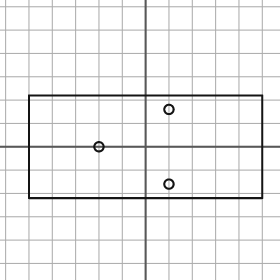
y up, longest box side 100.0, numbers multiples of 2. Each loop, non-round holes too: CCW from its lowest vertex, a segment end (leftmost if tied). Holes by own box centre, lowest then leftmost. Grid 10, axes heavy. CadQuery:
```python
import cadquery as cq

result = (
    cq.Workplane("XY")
    .moveTo(-50.0, -22.0)
    .lineTo(50.0, -22.0)
    .lineTo(50.0, 22.0)
    .lineTo(-50.0, 22.0)
    .close()
    .moveTo(10.0, -16.0)
    .circle(2.0)
    .moveTo(-20.0, 0.0)
    .circle(2.0)
    .moveTo(10.0, 16.0)
    .circle(2.0)
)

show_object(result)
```